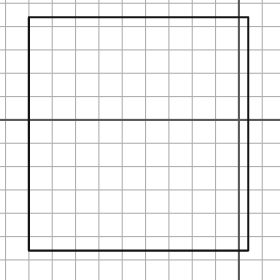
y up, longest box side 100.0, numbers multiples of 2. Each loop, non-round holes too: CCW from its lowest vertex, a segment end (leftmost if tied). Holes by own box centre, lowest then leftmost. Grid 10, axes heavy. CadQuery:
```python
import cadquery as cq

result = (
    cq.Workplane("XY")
    .moveTo(-90.0, -56.0)
    .lineTo(4.0, -56.0)
    .lineTo(4.0, 44.0)
    .lineTo(-90.0, 44.0)
    .close()
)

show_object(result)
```